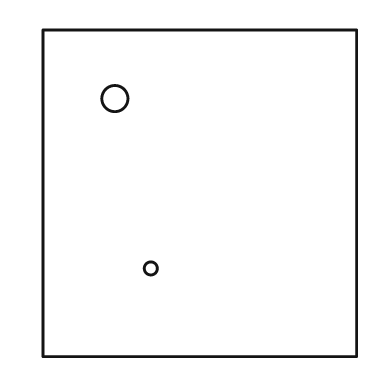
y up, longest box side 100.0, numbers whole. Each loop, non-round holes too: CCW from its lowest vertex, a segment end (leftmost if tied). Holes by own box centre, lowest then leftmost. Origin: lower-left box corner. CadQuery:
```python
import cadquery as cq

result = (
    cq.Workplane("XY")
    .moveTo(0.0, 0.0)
    .lineTo(96.0, 0.0)
    .lineTo(96.0, 100.0)
    .lineTo(0.0, 100.0)
    .close()
    .moveTo(33.0, 27.0)
    .circle(2.0)
    .moveTo(22.0, 79.0)
    .circle(4.0)
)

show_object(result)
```